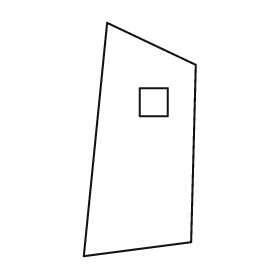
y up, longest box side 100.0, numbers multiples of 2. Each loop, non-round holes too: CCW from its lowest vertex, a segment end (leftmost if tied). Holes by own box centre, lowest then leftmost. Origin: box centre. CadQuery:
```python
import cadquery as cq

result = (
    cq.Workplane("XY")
    .moveTo(-24.0, -50.0)
    .lineTo(22.0, -44.0)
    .lineTo(24.0, 32.0)
    .lineTo(-14.0, 50.0)
    .close()
    .moveTo(0.0, 10.0)
    .lineTo(12.0, 10.0)
    .lineTo(12.0, 22.0)
    .lineTo(0.0, 22.0)
    .close()
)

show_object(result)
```